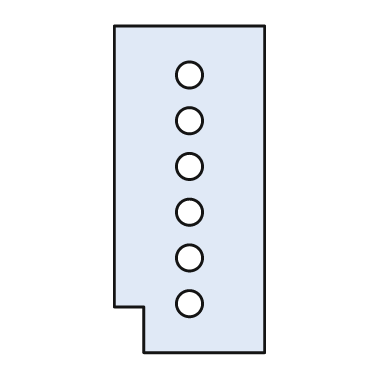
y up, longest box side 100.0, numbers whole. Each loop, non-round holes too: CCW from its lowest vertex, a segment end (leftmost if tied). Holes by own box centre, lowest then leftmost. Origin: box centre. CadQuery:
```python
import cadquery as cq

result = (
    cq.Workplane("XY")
    .moveTo(-14.0, -50.0)
    .lineTo(23.0, -50.0)
    .lineTo(23.0, 50.0)
    .lineTo(-23.0, 50.0)
    .lineTo(-23.0, -36.0)
    .lineTo(-14.0, -36.0)
    .close()
    .moveTo(0.0, -35.0)
    .circle(4.0)
    .moveTo(0.0, -21.0)
    .circle(4.0)
    .moveTo(0.0, -7.0)
    .circle(4.0)
    .moveTo(0.0, 7.0)
    .circle(4.0)
    .moveTo(0.0, 21.0)
    .circle(4.0)
    .moveTo(0.0, 35.0)
    .circle(4.0)
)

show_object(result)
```